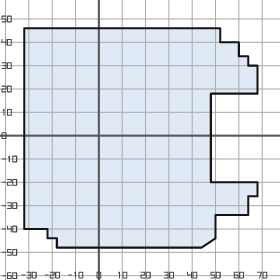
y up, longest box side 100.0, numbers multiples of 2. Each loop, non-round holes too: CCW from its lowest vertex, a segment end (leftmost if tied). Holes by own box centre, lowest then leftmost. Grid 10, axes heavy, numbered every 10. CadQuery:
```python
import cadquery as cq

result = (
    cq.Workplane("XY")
    .moveTo(-18.0, -48.0)
    .lineTo(44.0, -48.0)
    .lineTo(50.0, -44.0)
    .lineTo(50.0, -34.0)
    .lineTo(64.0, -34.0)
    .lineTo(64.0, -26.0)
    .lineTo(68.0, -26.0)
    .lineTo(68.0, -20.0)
    .lineTo(48.0, -20.0)
    .lineTo(48.0, 18.0)
    .lineTo(68.0, 18.0)
    .lineTo(68.0, 30.0)
    .lineTo(64.0, 30.0)
    .lineTo(64.0, 34.0)
    .lineTo(60.0, 34.0)
    .lineTo(60.0, 40.0)
    .lineTo(52.0, 40.0)
    .lineTo(52.0, 46.0)
    .lineTo(-32.0, 46.0)
    .lineTo(-32.0, -40.0)
    .lineTo(-22.0, -40.0)
    .lineTo(-22.0, -44.0)
    .lineTo(-18.0, -44.0)
    .close()
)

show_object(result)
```